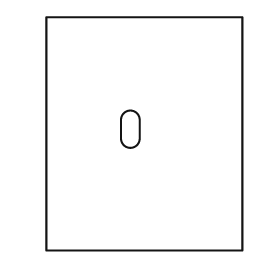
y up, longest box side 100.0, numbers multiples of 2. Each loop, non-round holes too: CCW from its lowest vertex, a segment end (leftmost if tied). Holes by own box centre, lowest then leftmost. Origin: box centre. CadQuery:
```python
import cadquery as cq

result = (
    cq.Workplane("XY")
    .moveTo(-42.0, -50.0)
    .lineTo(42.0, -50.0)
    .lineTo(42.0, 50.0)
    .lineTo(-42.0, 50.0)
    .close()
    .moveTo(-10.0, -2.0)
    .threePointArc((-6.0, -6.0), (-2.0, -2.0))
    .lineTo(-2.0, 6.0)
    .threePointArc((-6.0, 10.0), (-10.0, 6.0))
    .close()
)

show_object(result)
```